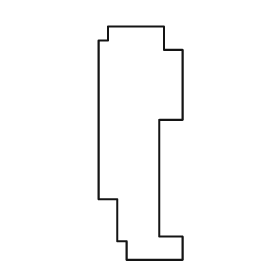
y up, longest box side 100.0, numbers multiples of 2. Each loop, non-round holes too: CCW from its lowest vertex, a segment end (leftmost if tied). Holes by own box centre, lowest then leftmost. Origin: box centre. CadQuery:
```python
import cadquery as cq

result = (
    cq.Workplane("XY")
    .moveTo(-6.0, -50.0)
    .lineTo(18.0, -50.0)
    .lineTo(18.0, -40.0)
    .lineTo(8.0, -40.0)
    .lineTo(8.0, 10.0)
    .lineTo(18.0, 10.0)
    .lineTo(18.0, 40.0)
    .lineTo(10.0, 40.0)
    .lineTo(10.0, 50.0)
    .lineTo(-14.0, 50.0)
    .lineTo(-14.0, 44.0)
    .lineTo(-18.0, 44.0)
    .lineTo(-18.0, -24.0)
    .lineTo(-10.0, -24.0)
    .lineTo(-10.0, -42.0)
    .lineTo(-6.0, -42.0)
    .close()
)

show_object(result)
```